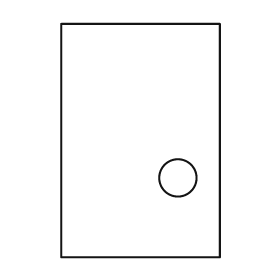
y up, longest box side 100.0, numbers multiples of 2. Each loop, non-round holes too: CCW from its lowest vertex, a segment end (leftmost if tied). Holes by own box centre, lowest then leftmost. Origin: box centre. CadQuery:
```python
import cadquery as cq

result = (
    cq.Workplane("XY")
    .moveTo(-34.0, -50.0)
    .lineTo(34.0, -50.0)
    .lineTo(34.0, 50.0)
    .lineTo(-34.0, 50.0)
    .close()
    .moveTo(16.0, -16.0)
    .circle(8.0)
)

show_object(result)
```